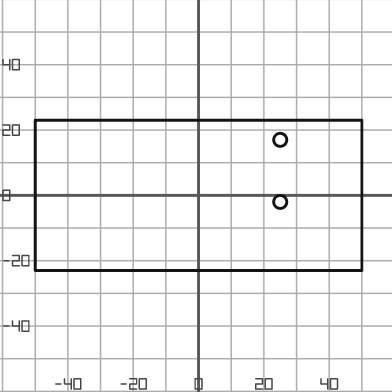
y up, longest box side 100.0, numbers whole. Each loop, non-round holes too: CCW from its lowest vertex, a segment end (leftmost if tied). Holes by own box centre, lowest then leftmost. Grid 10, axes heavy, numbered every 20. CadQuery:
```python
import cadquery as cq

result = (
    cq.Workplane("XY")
    .moveTo(-50.0, -23.0)
    .lineTo(50.0, -23.0)
    .lineTo(50.0, 23.0)
    .lineTo(-50.0, 23.0)
    .close()
    .moveTo(25.0, -2.0)
    .circle(2.0)
    .moveTo(25.0, 17.0)
    .circle(2.0)
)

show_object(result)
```